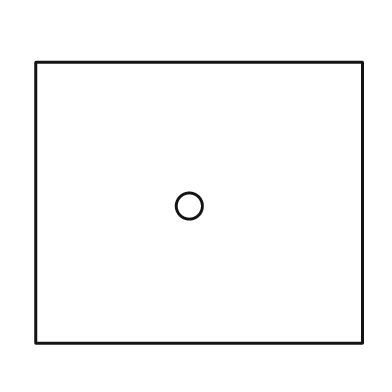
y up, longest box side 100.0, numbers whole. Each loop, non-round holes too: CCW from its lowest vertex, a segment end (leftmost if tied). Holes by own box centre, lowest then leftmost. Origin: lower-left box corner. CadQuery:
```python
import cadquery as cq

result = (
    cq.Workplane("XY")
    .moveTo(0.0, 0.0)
    .lineTo(100.0, 0.0)
    .lineTo(100.0, 86.0)
    .lineTo(0.0, 86.0)
    .close()
    .moveTo(47.0, 42.0)
    .circle(4.0)
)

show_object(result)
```